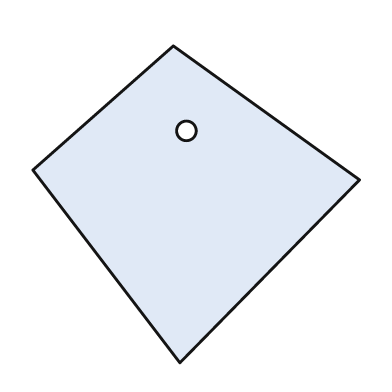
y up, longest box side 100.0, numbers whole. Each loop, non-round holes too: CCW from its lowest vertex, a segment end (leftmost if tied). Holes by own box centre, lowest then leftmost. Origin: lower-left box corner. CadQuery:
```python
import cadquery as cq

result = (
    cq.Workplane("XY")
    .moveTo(45.0, 0.0)
    .lineTo(100.0, 56.0)
    .lineTo(43.0, 97.0)
    .lineTo(0.0, 59.0)
    .close()
    .moveTo(47.0, 71.0)
    .circle(3.0)
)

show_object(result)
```